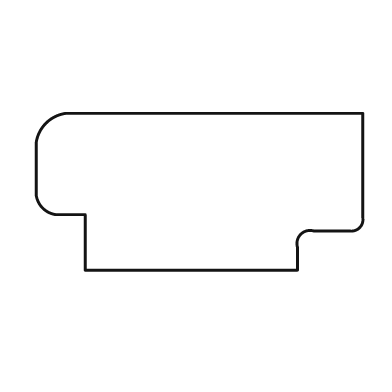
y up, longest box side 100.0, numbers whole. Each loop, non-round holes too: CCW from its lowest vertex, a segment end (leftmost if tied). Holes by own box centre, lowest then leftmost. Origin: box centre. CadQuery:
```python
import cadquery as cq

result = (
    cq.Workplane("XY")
    .moveTo(-35.0, -24.0)
    .lineTo(30.0, -24.0)
    .lineTo(30.0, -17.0)
    .threePointArc((31.0, -13.0), (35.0, -12.0))
    .lineTo(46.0, -12.0)
    .threePointArc((49.0, -11.0), (50.0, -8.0))
    .lineTo(50.0, 24.0)
    .lineTo(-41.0, 24.0)
    .threePointArc((-47.0, 21.0), (-50.0, 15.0))
    .lineTo(-50.0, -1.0)
    .threePointArc((-48.0, -5.0), (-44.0, -7.0))
    .lineTo(-35.0, -7.0)
    .close()
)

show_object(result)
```